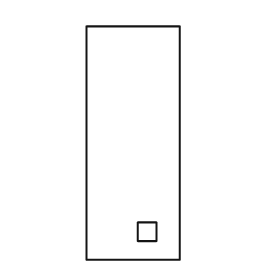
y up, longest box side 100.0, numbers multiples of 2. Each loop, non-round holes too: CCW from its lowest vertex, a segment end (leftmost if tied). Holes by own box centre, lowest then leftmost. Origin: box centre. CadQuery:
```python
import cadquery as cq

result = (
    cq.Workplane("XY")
    .moveTo(-20.0, -50.0)
    .lineTo(20.0, -50.0)
    .lineTo(20.0, 50.0)
    .lineTo(-20.0, 50.0)
    .close()
    .moveTo(2.0, -42.0)
    .lineTo(10.0, -42.0)
    .lineTo(10.0, -34.0)
    .lineTo(2.0, -34.0)
    .close()
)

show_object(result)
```